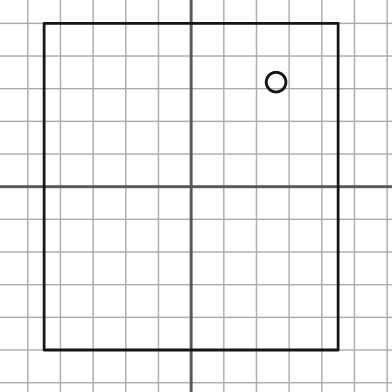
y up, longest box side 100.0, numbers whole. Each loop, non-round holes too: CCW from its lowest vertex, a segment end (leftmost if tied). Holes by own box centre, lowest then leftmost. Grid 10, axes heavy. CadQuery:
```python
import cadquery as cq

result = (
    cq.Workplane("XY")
    .moveTo(-45.0, -50.0)
    .lineTo(45.0, -50.0)
    .lineTo(45.0, 50.0)
    .lineTo(-45.0, 50.0)
    .close()
    .moveTo(26.0, 32.0)
    .circle(3.0)
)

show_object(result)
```